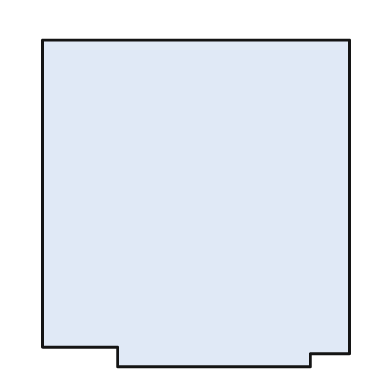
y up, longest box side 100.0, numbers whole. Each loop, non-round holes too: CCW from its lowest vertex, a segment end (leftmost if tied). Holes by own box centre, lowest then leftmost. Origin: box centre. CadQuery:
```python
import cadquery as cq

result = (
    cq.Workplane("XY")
    .moveTo(-24.0, -50.0)
    .lineTo(35.0, -50.0)
    .lineTo(35.0, -46.0)
    .lineTo(47.0, -46.0)
    .lineTo(47.0, 50.0)
    .lineTo(-47.0, 50.0)
    .lineTo(-47.0, -44.0)
    .lineTo(-24.0, -44.0)
    .close()
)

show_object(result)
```